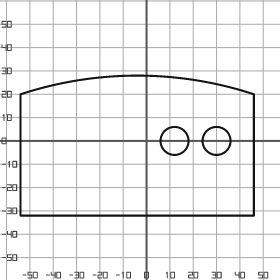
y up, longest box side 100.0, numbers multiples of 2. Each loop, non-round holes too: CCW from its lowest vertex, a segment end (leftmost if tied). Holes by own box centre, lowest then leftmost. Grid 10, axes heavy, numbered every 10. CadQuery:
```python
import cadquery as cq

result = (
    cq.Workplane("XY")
    .moveTo(-54.0, -32.0)
    .lineTo(46.0, -32.0)
    .lineTo(46.0, 20.0)
    .threePointArc((-4.0, 28.0), (-54.0, 20.0))
    .close()
    .moveTo(12.0, 0.0)
    .circle(6.0)
    .moveTo(30.0, 0.0)
    .circle(6.0)
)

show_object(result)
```